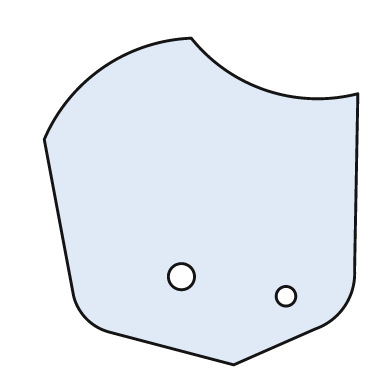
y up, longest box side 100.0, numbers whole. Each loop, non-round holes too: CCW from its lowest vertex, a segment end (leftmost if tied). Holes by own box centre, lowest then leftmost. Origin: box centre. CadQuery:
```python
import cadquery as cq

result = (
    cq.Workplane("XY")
    .moveTo(10.0, -50.0)
    .lineTo(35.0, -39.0)
    .threePointArc((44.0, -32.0), (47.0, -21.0))
    .lineTo(48.0, 33.0)
    .threePointArc((20.0, 34.0), (-3.0, 50.0))
    .threePointArc((-30.0, 41.0), (-48.0, 19.0))
    .lineTo(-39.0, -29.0)
    .threePointArc((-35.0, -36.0), (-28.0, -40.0))
    .close()
    .moveTo(26.0, -29.0)
    .circle(3.0)
    .moveTo(-6.0, -23.0)
    .circle(4.0)
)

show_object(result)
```